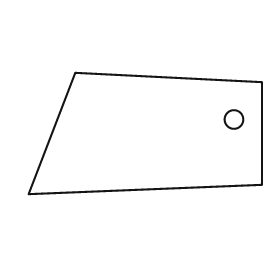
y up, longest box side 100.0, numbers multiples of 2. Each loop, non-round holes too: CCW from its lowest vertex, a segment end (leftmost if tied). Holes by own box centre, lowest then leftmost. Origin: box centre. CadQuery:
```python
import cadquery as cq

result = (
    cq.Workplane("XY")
    .moveTo(-50.0, -26.0)
    .lineTo(50.0, -22.0)
    .lineTo(50.0, 22.0)
    .lineTo(-30.0, 26.0)
    .close()
    .moveTo(38.0, 6.0)
    .circle(4.0)
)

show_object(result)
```